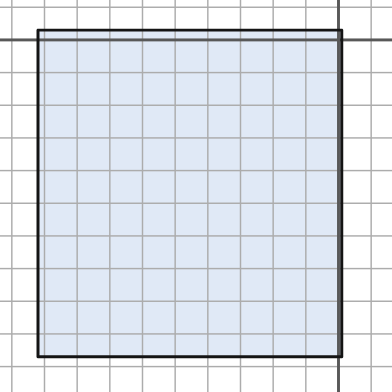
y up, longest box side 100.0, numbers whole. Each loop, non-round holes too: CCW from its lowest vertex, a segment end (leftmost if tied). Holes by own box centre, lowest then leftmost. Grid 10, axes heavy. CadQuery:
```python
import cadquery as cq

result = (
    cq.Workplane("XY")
    .moveTo(-92.0, -97.0)
    .lineTo(1.0, -97.0)
    .lineTo(1.0, 3.0)
    .lineTo(-92.0, 3.0)
    .close()
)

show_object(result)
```